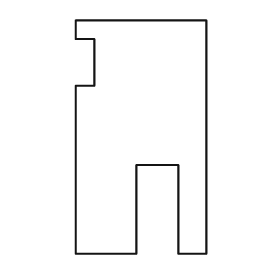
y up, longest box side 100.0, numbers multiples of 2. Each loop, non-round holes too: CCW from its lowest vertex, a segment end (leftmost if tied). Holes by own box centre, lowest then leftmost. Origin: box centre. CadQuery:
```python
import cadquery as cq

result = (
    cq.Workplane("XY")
    .moveTo(-28.0, -50.0)
    .lineTo(-2.0, -50.0)
    .lineTo(-2.0, -12.0)
    .lineTo(16.0, -12.0)
    .lineTo(16.0, -50.0)
    .lineTo(28.0, -50.0)
    .lineTo(28.0, 50.0)
    .lineTo(-28.0, 50.0)
    .lineTo(-28.0, 42.0)
    .lineTo(-20.0, 42.0)
    .lineTo(-20.0, 22.0)
    .lineTo(-28.0, 22.0)
    .close()
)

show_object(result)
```